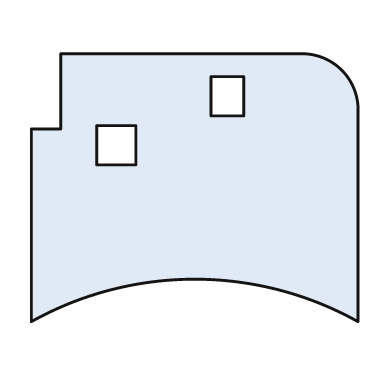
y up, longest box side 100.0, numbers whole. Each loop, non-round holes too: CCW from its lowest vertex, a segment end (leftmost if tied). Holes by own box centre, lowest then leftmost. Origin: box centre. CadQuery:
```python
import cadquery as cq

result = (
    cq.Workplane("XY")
    .moveTo(-50.0, -41.0)
    .threePointArc((0.0, -28.0), (50.0, -41.0))
    .lineTo(50.0, 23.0)
    .threePointArc((45.0, 36.0), (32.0, 41.0))
    .lineTo(-41.0, 41.0)
    .lineTo(-41.0, 18.0)
    .lineTo(-50.0, 18.0)
    .close()
    .moveTo(-30.0, 7.0)
    .lineTo(-18.0, 7.0)
    .lineTo(-18.0, 19.0)
    .lineTo(-30.0, 19.0)
    .close()
    .moveTo(5.0, 22.0)
    .lineTo(15.0, 22.0)
    .lineTo(15.0, 34.0)
    .lineTo(5.0, 34.0)
    .close()
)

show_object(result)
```